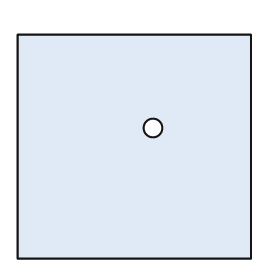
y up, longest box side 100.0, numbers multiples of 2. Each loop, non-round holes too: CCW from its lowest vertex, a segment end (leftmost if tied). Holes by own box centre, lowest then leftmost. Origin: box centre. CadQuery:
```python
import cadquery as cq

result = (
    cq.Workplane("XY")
    .moveTo(-50.0, -48.0)
    .lineTo(50.0, -48.0)
    .lineTo(50.0, 48.0)
    .lineTo(-50.0, 48.0)
    .close()
    .moveTo(8.0, 8.0)
    .circle(4.0)
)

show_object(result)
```